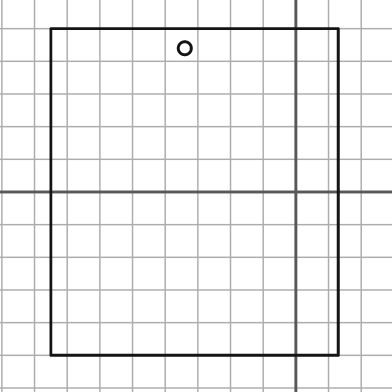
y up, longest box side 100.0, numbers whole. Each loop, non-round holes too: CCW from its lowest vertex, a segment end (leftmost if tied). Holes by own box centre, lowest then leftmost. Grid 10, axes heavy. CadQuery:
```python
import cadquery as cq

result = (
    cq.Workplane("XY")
    .moveTo(-75.0, -50.0)
    .lineTo(13.0, -50.0)
    .lineTo(13.0, 50.0)
    .lineTo(-75.0, 50.0)
    .close()
    .moveTo(-34.0, 44.0)
    .circle(2.0)
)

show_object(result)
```